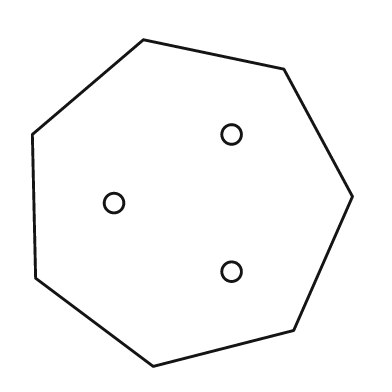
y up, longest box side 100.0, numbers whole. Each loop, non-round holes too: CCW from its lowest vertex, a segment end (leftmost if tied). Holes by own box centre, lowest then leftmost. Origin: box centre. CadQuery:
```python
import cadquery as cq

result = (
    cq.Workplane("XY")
    .moveTo(-12.0, -50.0)
    .lineTo(31.0, -39.0)
    .lineTo(49.0, 2.0)
    .lineTo(28.0, 41.0)
    .lineTo(-15.0, 50.0)
    .lineTo(-49.0, 21.0)
    .lineTo(-48.0, -23.0)
    .close()
    .moveTo(12.0, -21.0)
    .circle(3.0)
    .moveTo(-24.0, 0.0)
    .circle(3.0)
    .moveTo(12.0, 21.0)
    .circle(3.0)
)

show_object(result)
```